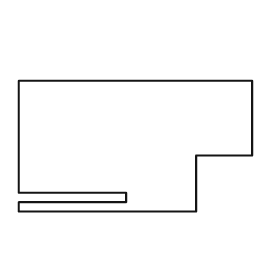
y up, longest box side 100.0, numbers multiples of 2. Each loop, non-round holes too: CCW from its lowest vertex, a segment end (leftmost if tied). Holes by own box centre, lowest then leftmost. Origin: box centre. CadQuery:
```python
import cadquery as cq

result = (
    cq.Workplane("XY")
    .moveTo(-50.0, -28.0)
    .lineTo(26.0, -28.0)
    .lineTo(26.0, -4.0)
    .lineTo(50.0, -4.0)
    .lineTo(50.0, 28.0)
    .lineTo(-50.0, 28.0)
    .lineTo(-50.0, -20.0)
    .lineTo(-4.0, -20.0)
    .lineTo(-4.0, -24.0)
    .lineTo(-50.0, -24.0)
    .close()
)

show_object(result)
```